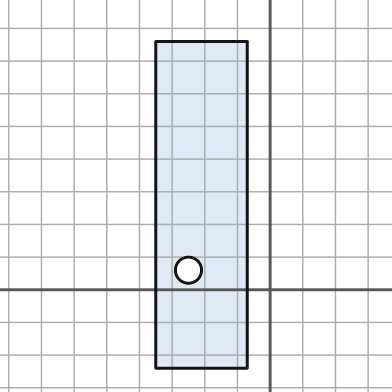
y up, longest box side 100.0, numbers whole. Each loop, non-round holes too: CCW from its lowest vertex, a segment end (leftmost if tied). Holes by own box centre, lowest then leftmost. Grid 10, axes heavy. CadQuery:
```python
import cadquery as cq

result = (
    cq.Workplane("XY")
    .moveTo(-35.0, -24.0)
    .lineTo(-7.0, -24.0)
    .lineTo(-7.0, 76.0)
    .lineTo(-35.0, 76.0)
    .close()
    .moveTo(-25.0, 6.0)
    .circle(4.0)
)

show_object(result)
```